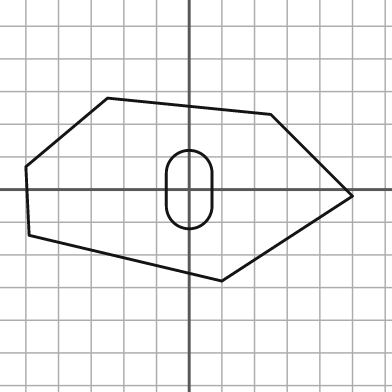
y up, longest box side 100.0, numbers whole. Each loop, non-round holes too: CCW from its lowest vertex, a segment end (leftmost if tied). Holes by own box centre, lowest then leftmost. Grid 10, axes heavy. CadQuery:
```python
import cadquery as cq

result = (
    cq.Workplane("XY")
    .moveTo(10.0, -28.0)
    .lineTo(50.0, -2.0)
    .lineTo(25.0, 23.0)
    .lineTo(-25.0, 28.0)
    .lineTo(-50.0, 7.0)
    .lineTo(-49.0, -14.0)
    .close()
    .moveTo(-7.0, -5.0)
    .threePointArc((0.0, -12.0), (7.0, -5.0))
    .lineTo(7.0, 5.0)
    .threePointArc((0.0, 12.0), (-7.0, 5.0))
    .close()
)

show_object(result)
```